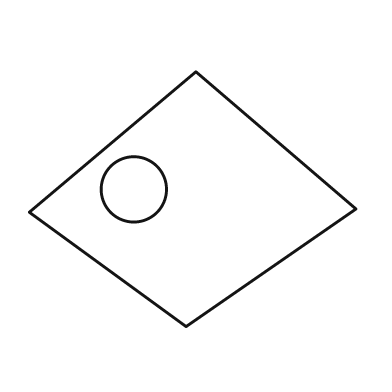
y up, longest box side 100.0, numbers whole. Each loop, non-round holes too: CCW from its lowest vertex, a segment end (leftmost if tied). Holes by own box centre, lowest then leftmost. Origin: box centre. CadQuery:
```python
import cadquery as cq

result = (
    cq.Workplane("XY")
    .moveTo(-2.0, -39.0)
    .lineTo(50.0, -3.0)
    .lineTo(1.0, 39.0)
    .lineTo(-50.0, -4.0)
    .close()
    .moveTo(-18.0, 3.0)
    .circle(10.0)
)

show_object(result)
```